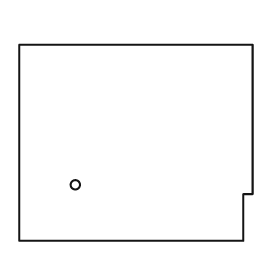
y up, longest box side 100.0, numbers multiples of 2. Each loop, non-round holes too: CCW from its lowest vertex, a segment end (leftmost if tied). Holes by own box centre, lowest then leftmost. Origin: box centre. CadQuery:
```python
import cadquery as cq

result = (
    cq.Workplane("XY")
    .moveTo(-50.0, -42.0)
    .lineTo(46.0, -42.0)
    .lineTo(46.0, -22.0)
    .lineTo(50.0, -22.0)
    .lineTo(50.0, 42.0)
    .lineTo(-50.0, 42.0)
    .close()
    .moveTo(-26.0, -18.0)
    .circle(2.0)
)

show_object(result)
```